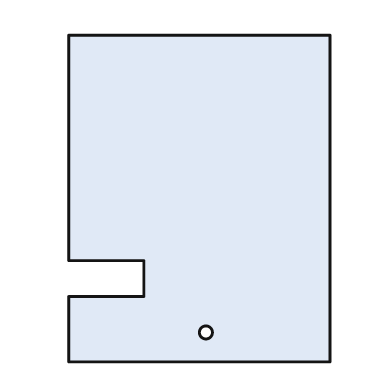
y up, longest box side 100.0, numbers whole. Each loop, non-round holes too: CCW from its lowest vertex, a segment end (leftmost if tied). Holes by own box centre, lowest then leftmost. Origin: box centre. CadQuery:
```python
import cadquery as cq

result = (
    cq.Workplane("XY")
    .moveTo(-40.0, -50.0)
    .lineTo(40.0, -50.0)
    .lineTo(40.0, 50.0)
    .lineTo(-40.0, 50.0)
    .lineTo(-40.0, -19.0)
    .lineTo(-17.0, -19.0)
    .lineTo(-17.0, -30.0)
    .lineTo(-40.0, -30.0)
    .close()
    .moveTo(2.0, -41.0)
    .circle(2.0)
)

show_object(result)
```